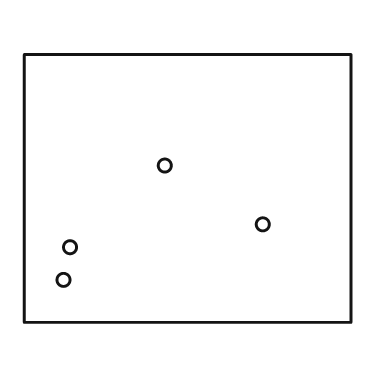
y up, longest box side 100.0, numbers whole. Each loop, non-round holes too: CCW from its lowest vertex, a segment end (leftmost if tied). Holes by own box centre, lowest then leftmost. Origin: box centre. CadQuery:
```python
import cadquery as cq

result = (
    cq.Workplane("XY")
    .moveTo(-50.0, -41.0)
    .lineTo(50.0, -41.0)
    .lineTo(50.0, 41.0)
    .lineTo(-50.0, 41.0)
    .close()
    .moveTo(-38.0, -28.0)
    .circle(2.0)
    .moveTo(-36.0, -18.0)
    .circle(2.0)
    .moveTo(23.0, -11.0)
    .circle(2.0)
    .moveTo(-7.0, 7.0)
    .circle(2.0)
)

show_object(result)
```